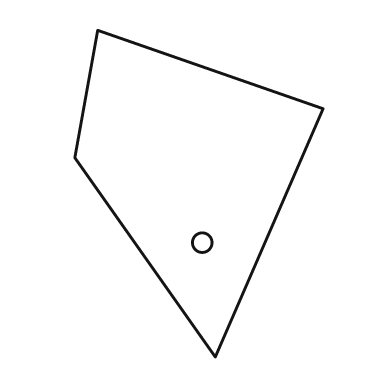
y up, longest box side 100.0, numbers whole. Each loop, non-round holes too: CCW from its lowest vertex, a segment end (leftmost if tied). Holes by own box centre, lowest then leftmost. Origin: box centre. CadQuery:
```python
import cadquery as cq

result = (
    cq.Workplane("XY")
    .moveTo(5.0, -50.0)
    .lineTo(38.0, 26.0)
    .lineTo(-31.0, 50.0)
    .lineTo(-38.0, 11.0)
    .close()
    .moveTo(1.0, -15.0)
    .circle(3.0)
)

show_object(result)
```